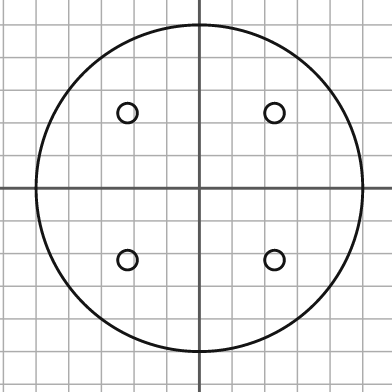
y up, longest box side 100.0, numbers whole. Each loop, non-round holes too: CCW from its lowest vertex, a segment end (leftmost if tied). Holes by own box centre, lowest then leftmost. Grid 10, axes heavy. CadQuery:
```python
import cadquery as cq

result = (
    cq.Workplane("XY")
    .moveTo(0.0, 0.0)
    .circle(50.0)
    .moveTo(-22.0, -22.0)
    .circle(3.0)
    .moveTo(23.0, -22.0)
    .circle(3.0)
    .moveTo(-22.0, 23.0)
    .circle(3.0)
    .moveTo(23.0, 23.0)
    .circle(3.0)
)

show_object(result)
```